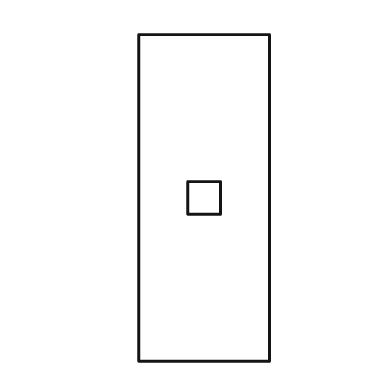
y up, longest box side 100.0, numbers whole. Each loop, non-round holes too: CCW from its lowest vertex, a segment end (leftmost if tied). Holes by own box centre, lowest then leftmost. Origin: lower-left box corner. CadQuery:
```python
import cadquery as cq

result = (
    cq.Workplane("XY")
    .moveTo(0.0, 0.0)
    .lineTo(40.0, 0.0)
    .lineTo(40.0, 100.0)
    .lineTo(0.0, 100.0)
    .close()
    .moveTo(15.0, 45.0)
    .lineTo(25.0, 45.0)
    .lineTo(25.0, 55.0)
    .lineTo(15.0, 55.0)
    .close()
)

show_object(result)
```